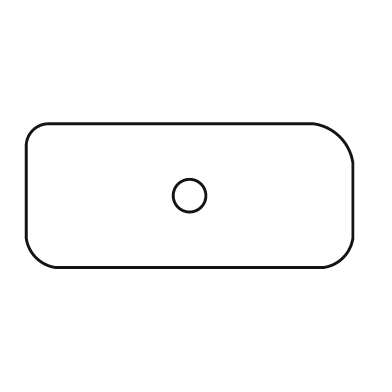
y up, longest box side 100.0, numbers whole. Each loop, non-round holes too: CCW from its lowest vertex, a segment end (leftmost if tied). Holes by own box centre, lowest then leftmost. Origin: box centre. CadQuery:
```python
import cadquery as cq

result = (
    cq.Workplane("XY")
    .moveTo(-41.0, -22.0)
    .lineTo(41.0, -22.0)
    .threePointArc((47.0, -19.0), (50.0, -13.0))
    .lineTo(50.0, 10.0)
    .threePointArc((46.0, 18.0), (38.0, 22.0))
    .lineTo(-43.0, 22.0)
    .threePointArc((-48.0, 20.0), (-50.0, 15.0))
    .lineTo(-50.0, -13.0)
    .threePointArc((-47.0, -19.0), (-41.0, -22.0))
    .close()
    .moveTo(0.0, 0.0)
    .circle(5.0)
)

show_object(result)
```